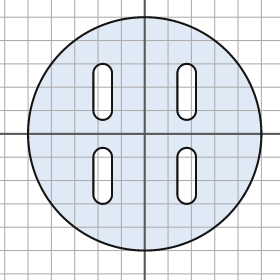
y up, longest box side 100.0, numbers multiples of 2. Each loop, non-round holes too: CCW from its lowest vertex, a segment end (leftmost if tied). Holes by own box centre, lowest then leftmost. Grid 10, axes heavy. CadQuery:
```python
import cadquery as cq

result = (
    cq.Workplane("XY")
    .moveTo(0.0, 0.0)
    .circle(50.0)
    .moveTo(-22.0, -26.0)
    .threePointArc((-18.0, -30.0), (-14.0, -26.0))
    .lineTo(-14.0, -10.0)
    .threePointArc((-18.0, -6.0), (-22.0, -10.0))
    .close()
    .moveTo(14.0, -26.0)
    .threePointArc((18.0, -30.0), (22.0, -26.0))
    .lineTo(22.0, -10.0)
    .threePointArc((18.0, -6.0), (14.0, -10.0))
    .close()
    .moveTo(-22.0, 10.0)
    .threePointArc((-18.0, 6.0), (-14.0, 10.0))
    .lineTo(-14.0, 26.0)
    .threePointArc((-18.0, 30.0), (-22.0, 26.0))
    .close()
    .moveTo(14.0, 10.0)
    .threePointArc((18.0, 6.0), (22.0, 10.0))
    .lineTo(22.0, 26.0)
    .threePointArc((18.0, 30.0), (14.0, 26.0))
    .close()
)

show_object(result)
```